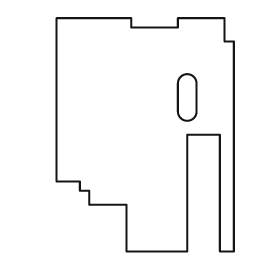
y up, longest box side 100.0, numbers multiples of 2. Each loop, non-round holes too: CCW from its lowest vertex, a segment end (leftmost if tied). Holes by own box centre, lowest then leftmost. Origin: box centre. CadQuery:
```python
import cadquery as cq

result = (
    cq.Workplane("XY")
    .moveTo(-8.0, -50.0)
    .lineTo(18.0, -50.0)
    .lineTo(18.0, 0.0)
    .lineTo(32.0, 0.0)
    .lineTo(32.0, -50.0)
    .lineTo(38.0, -50.0)
    .lineTo(38.0, 40.0)
    .lineTo(34.0, 40.0)
    .lineTo(34.0, 50.0)
    .lineTo(14.0, 50.0)
    .lineTo(14.0, 46.0)
    .lineTo(-6.0, 46.0)
    .lineTo(-6.0, 50.0)
    .lineTo(-38.0, 50.0)
    .lineTo(-38.0, -20.0)
    .lineTo(-28.0, -20.0)
    .lineTo(-28.0, -24.0)
    .lineTo(-24.0, -24.0)
    .lineTo(-24.0, -30.0)
    .lineTo(-8.0, -30.0)
    .close()
    .moveTo(14.0, 10.0)
    .threePointArc((18.0, 6.0), (22.0, 10.0))
    .lineTo(22.0, 22.0)
    .threePointArc((18.0, 26.0), (14.0, 22.0))
    .close()
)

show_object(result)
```